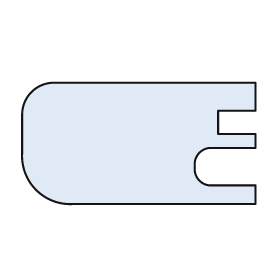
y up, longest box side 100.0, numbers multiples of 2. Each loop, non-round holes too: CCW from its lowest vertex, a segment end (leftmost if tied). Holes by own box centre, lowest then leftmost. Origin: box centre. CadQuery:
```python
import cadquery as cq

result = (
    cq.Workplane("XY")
    .moveTo(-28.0, -26.0)
    .lineTo(50.0, -26.0)
    .lineTo(50.0, -18.0)
    .lineTo(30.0, -18.0)
    .threePointArc((26.0, -16.0), (24.0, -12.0))
    .lineTo(24.0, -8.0)
    .threePointArc((26.0, -4.0), (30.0, -2.0))
    .lineTo(50.0, -2.0)
    .lineTo(50.0, 4.0)
    .lineTo(34.0, 4.0)
    .lineTo(34.0, 14.0)
    .lineTo(50.0, 14.0)
    .lineTo(50.0, 26.0)
    .lineTo(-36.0, 26.0)
    .threePointArc((-46.0, 22.0), (-50.0, 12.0))
    .lineTo(-50.0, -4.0)
    .threePointArc((-44.0, -20.0), (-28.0, -26.0))
    .close()
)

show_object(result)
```